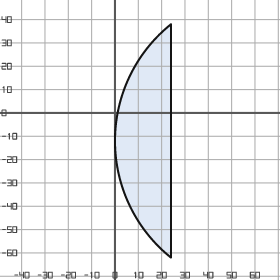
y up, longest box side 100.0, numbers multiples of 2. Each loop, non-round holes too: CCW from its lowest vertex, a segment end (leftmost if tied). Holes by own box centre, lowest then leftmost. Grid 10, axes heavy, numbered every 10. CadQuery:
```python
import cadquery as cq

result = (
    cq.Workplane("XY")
    .moveTo(24.0, -62.0)
    .lineTo(24.0, 38.0)
    .threePointArc((0.0, -12.0), (24.0, -62.0))
    .close()
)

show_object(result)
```